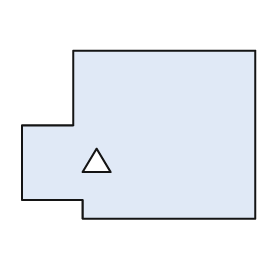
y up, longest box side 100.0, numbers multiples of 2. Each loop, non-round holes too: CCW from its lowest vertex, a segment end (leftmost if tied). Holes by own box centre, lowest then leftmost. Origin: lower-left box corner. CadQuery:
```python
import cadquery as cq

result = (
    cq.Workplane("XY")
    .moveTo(26.0, 0.0)
    .lineTo(100.0, 0.0)
    .lineTo(100.0, 72.0)
    .lineTo(22.0, 72.0)
    .lineTo(22.0, 40.0)
    .lineTo(0.0, 40.0)
    .lineTo(0.0, 8.0)
    .lineTo(26.0, 8.0)
    .close()
    .moveTo(26.0, 20.0)
    .lineTo(38.0, 20.0)
    .lineTo(32.0, 30.0)
    .close()
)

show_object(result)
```